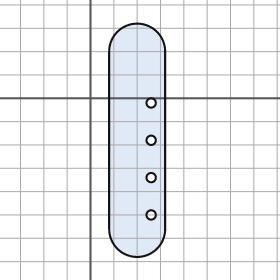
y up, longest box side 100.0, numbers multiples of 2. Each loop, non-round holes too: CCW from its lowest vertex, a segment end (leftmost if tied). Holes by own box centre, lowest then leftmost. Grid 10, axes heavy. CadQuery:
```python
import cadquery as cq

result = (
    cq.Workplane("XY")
    .moveTo(8.0, -56.0)
    .threePointArc((20.0, -68.0), (32.0, -56.0))
    .lineTo(32.0, 20.0)
    .threePointArc((20.0, 32.0), (8.0, 20.0))
    .close()
    .moveTo(26.0, -50.0)
    .circle(2.0)
    .moveTo(26.0, -34.0)
    .circle(2.0)
    .moveTo(26.0, -18.0)
    .circle(2.0)
    .moveTo(26.0, -2.0)
    .circle(2.0)
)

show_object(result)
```